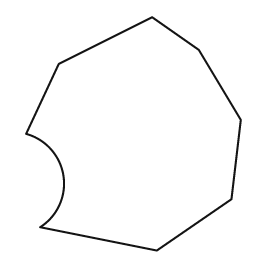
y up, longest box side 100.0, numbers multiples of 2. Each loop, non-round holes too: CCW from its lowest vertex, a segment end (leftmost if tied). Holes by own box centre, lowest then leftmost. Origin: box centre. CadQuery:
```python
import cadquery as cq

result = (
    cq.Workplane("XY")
    .moveTo(10.0, -50.0)
    .lineTo(42.0, -28.0)
    .lineTo(46.0, 6.0)
    .lineTo(28.0, 36.0)
    .lineTo(8.0, 50.0)
    .lineTo(-32.0, 30.0)
    .lineTo(-46.0, 0.0)
    .threePointArc((-30.0, -18.0), (-40.0, -40.0))
    .close()
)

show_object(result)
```